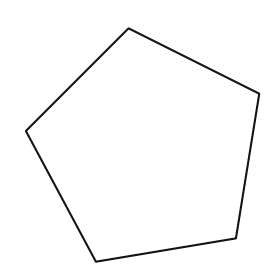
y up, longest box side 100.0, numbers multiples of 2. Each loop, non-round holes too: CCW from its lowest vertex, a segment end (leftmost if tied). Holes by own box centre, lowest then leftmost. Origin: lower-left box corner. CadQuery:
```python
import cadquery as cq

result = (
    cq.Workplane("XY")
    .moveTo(30.0, 0.0)
    .lineTo(90.0, 10.0)
    .lineTo(100.0, 72.0)
    .lineTo(44.0, 100.0)
    .lineTo(0.0, 56.0)
    .close()
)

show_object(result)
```